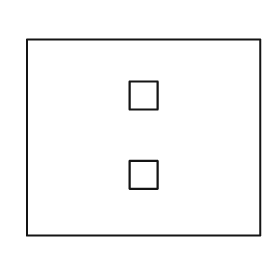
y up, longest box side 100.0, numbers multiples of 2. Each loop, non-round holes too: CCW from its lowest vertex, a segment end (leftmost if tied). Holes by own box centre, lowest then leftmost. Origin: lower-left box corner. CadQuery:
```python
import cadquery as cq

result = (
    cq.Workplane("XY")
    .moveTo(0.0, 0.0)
    .lineTo(100.0, 0.0)
    .lineTo(100.0, 84.0)
    .lineTo(0.0, 84.0)
    .close()
    .moveTo(44.0, 20.0)
    .lineTo(56.0, 20.0)
    .lineTo(56.0, 32.0)
    .lineTo(44.0, 32.0)
    .close()
    .moveTo(44.0, 54.0)
    .lineTo(56.0, 54.0)
    .lineTo(56.0, 66.0)
    .lineTo(44.0, 66.0)
    .close()
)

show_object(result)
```